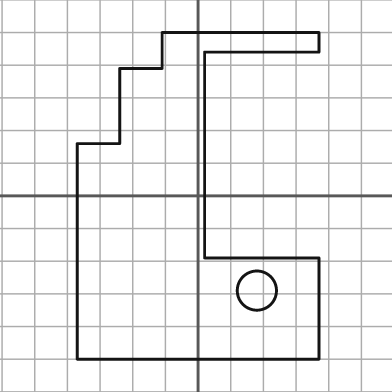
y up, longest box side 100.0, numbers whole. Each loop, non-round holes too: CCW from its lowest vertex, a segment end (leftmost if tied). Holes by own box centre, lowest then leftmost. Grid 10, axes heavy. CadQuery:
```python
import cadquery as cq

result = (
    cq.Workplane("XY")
    .moveTo(-37.0, -50.0)
    .lineTo(37.0, -50.0)
    .lineTo(37.0, -19.0)
    .lineTo(2.0, -19.0)
    .lineTo(2.0, 44.0)
    .lineTo(37.0, 44.0)
    .lineTo(37.0, 50.0)
    .lineTo(-11.0, 50.0)
    .lineTo(-11.0, 39.0)
    .lineTo(-24.0, 39.0)
    .lineTo(-24.0, 16.0)
    .lineTo(-37.0, 16.0)
    .close()
    .moveTo(18.0, -29.0)
    .circle(6.0)
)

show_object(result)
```